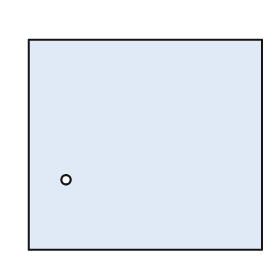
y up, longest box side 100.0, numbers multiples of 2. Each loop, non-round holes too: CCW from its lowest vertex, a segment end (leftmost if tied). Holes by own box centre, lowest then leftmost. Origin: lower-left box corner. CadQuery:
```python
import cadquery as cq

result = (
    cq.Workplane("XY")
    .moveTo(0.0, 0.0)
    .lineTo(100.0, 0.0)
    .lineTo(100.0, 90.0)
    .lineTo(0.0, 90.0)
    .close()
    .moveTo(16.0, 30.0)
    .circle(2.0)
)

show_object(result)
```